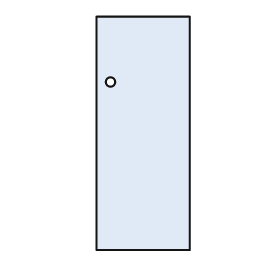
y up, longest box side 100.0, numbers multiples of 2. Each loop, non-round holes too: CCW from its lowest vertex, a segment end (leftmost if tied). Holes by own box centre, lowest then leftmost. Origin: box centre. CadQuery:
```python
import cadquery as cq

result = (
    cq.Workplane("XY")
    .moveTo(-20.0, -50.0)
    .lineTo(20.0, -50.0)
    .lineTo(20.0, 50.0)
    .lineTo(-20.0, 50.0)
    .close()
    .moveTo(-14.0, 22.0)
    .circle(2.0)
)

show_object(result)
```